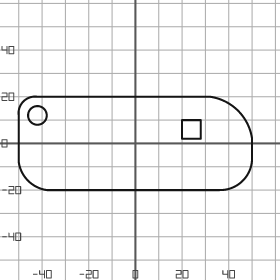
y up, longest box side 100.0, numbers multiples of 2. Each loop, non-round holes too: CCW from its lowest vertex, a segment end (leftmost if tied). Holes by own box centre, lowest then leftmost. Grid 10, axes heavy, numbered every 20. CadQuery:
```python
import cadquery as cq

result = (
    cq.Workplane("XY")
    .moveTo(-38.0, -20.0)
    .lineTo(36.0, -20.0)
    .threePointArc((46.0, -16.0), (50.0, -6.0))
    .lineTo(50.0, 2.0)
    .threePointArc((44.0, 14.0), (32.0, 20.0))
    .lineTo(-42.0, 20.0)
    .threePointArc((-48.0, 18.0), (-50.0, 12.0))
    .lineTo(-50.0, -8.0)
    .threePointArc((-46.0, -16.0), (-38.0, -20.0))
    .close()
    .moveTo(20.0, 2.0)
    .lineTo(28.0, 2.0)
    .lineTo(28.0, 10.0)
    .lineTo(20.0, 10.0)
    .close()
    .moveTo(-42.0, 12.0)
    .circle(4.0)
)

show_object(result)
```